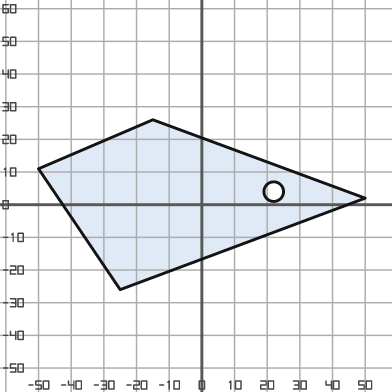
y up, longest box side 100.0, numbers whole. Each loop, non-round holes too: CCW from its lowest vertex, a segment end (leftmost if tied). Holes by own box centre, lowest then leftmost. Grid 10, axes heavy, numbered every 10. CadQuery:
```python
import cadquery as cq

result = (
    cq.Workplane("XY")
    .moveTo(-25.0, -26.0)
    .lineTo(50.0, 2.0)
    .lineTo(-15.0, 26.0)
    .lineTo(-50.0, 11.0)
    .close()
    .moveTo(22.0, 4.0)
    .circle(3.0)
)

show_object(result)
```